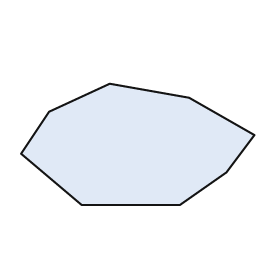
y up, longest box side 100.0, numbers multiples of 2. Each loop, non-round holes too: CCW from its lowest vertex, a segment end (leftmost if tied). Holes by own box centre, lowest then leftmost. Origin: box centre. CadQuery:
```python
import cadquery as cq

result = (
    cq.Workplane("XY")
    .moveTo(-24.0, -26.0)
    .lineTo(18.0, -26.0)
    .lineTo(38.0, -12.0)
    .lineTo(50.0, 4.0)
    .lineTo(22.0, 20.0)
    .lineTo(-12.0, 26.0)
    .lineTo(-38.0, 14.0)
    .lineTo(-50.0, -4.0)
    .close()
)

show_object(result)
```